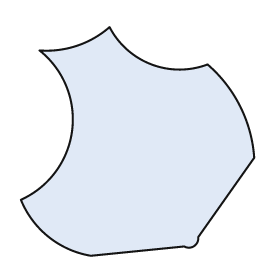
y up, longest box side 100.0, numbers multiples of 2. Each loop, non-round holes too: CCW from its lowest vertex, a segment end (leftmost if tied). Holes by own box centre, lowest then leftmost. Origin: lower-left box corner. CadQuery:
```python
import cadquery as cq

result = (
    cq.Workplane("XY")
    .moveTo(30.0, 0.0)
    .lineTo(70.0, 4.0)
    .threePointArc((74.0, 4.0), (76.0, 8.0))
    .lineTo(100.0, 42.0)
    .threePointArc((94.0, 64.0), (80.0, 82.0))
    .threePointArc((56.0, 82.0), (38.0, 98.0))
    .threePointArc((24.0, 90.0), (8.0, 88.0))
    .threePointArc((22.0, 54.0), (0.0, 24.0))
    .threePointArc((12.0, 8.0), (30.0, 0.0))
    .close()
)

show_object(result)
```